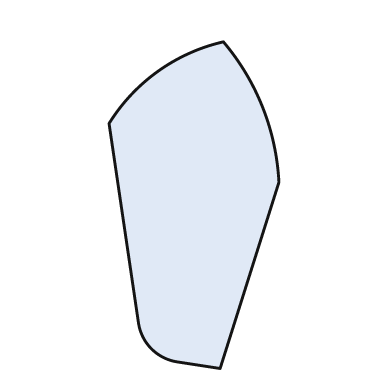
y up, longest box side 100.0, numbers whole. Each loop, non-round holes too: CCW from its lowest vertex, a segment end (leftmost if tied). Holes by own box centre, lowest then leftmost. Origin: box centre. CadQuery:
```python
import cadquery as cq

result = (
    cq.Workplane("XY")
    .moveTo(8.0, -50.0)
    .lineTo(26.0, 7.0)
    .threePointArc((21.0, 30.0), (9.0, 50.0))
    .threePointArc((-11.0, 41.0), (-26.0, 25.0))
    .lineTo(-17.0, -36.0)
    .threePointArc((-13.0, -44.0), (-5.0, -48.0))
    .close()
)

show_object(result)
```